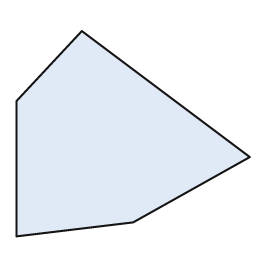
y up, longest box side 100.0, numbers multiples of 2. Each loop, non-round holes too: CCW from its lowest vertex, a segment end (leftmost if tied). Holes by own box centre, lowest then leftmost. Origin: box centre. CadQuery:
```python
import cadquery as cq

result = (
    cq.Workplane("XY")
    .moveTo(-50.0, -44.0)
    .lineTo(0.0, -38.0)
    .lineTo(50.0, -10.0)
    .lineTo(-22.0, 44.0)
    .lineTo(-50.0, 14.0)
    .close()
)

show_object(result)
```